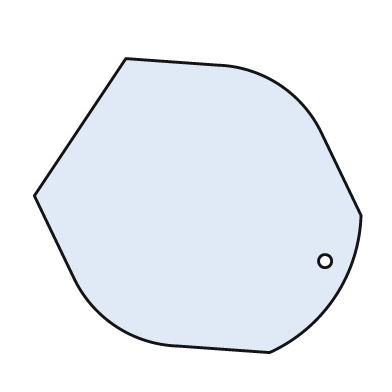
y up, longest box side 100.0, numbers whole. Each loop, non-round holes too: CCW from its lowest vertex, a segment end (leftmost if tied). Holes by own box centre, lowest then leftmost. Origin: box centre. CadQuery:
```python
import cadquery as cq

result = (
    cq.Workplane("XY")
    .moveTo(22.0, -45.0)
    .threePointArc((42.0, -28.0), (50.0, -3.0))
    .lineTo(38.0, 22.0)
    .threePointArc((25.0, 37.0), (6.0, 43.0))
    .lineTo(-22.0, 45.0)
    .lineTo(-50.0, 3.0)
    .lineTo(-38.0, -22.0)
    .threePointArc((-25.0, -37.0), (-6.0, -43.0))
    .close()
    .moveTo(39.0, -17.0)
    .circle(2.0)
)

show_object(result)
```